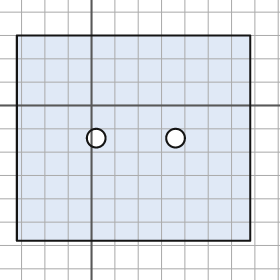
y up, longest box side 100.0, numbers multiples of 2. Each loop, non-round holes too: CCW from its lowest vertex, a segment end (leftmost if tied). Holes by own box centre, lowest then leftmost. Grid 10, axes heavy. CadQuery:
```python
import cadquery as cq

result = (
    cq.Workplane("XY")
    .moveTo(-32.0, -58.0)
    .lineTo(68.0, -58.0)
    .lineTo(68.0, 30.0)
    .lineTo(-32.0, 30.0)
    .close()
    .moveTo(2.0, -14.0)
    .circle(4.0)
    .moveTo(36.0, -14.0)
    .circle(4.0)
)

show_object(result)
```